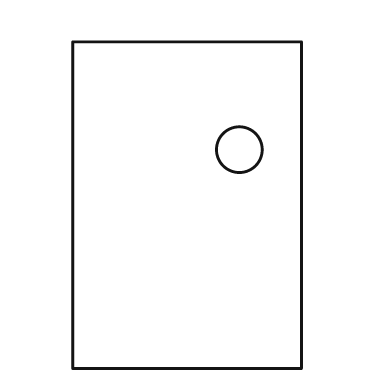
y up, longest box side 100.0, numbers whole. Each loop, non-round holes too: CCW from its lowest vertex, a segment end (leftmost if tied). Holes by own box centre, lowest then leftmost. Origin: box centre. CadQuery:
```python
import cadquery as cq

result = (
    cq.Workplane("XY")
    .moveTo(-35.0, -50.0)
    .lineTo(35.0, -50.0)
    .lineTo(35.0, 50.0)
    .lineTo(-35.0, 50.0)
    .close()
    .moveTo(16.0, 17.0)
    .circle(7.0)
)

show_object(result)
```